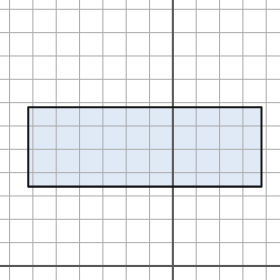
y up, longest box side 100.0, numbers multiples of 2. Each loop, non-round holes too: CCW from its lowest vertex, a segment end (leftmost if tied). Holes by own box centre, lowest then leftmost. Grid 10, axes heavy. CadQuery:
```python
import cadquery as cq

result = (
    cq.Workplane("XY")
    .moveTo(-62.0, 34.0)
    .lineTo(38.0, 34.0)
    .lineTo(38.0, 68.0)
    .lineTo(-62.0, 68.0)
    .close()
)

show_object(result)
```